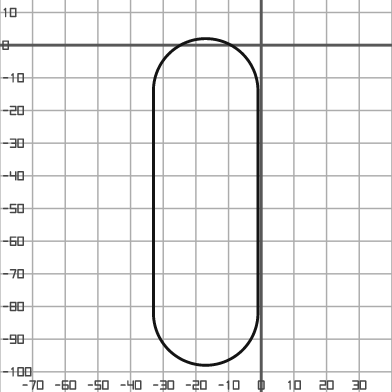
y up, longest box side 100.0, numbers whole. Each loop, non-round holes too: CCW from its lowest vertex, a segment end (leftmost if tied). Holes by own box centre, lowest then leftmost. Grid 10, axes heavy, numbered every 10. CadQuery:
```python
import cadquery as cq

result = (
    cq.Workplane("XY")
    .moveTo(-33.0, -82.0)
    .threePointArc((-17.0, -98.0), (-1.0, -82.0))
    .lineTo(-1.0, -14.0)
    .threePointArc((-17.0, 2.0), (-33.0, -14.0))
    .close()
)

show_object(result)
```